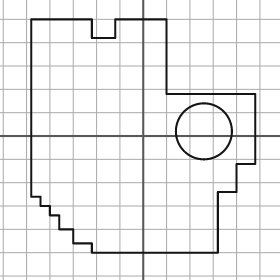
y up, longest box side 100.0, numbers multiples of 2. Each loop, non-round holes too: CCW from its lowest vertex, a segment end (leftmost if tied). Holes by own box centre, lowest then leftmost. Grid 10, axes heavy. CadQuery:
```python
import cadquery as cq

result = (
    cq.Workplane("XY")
    .moveTo(-22.0, -50.0)
    .lineTo(32.0, -50.0)
    .lineTo(32.0, -24.0)
    .lineTo(40.0, -24.0)
    .lineTo(40.0, -12.0)
    .lineTo(48.0, -12.0)
    .lineTo(48.0, 18.0)
    .lineTo(10.0, 18.0)
    .lineTo(10.0, 50.0)
    .lineTo(-12.0, 50.0)
    .lineTo(-12.0, 42.0)
    .lineTo(-22.0, 42.0)
    .lineTo(-22.0, 50.0)
    .lineTo(-48.0, 50.0)
    .lineTo(-48.0, -26.0)
    .lineTo(-44.0, -26.0)
    .lineTo(-44.0, -30.0)
    .lineTo(-40.0, -30.0)
    .lineTo(-40.0, -34.0)
    .lineTo(-36.0, -34.0)
    .lineTo(-36.0, -40.0)
    .lineTo(-30.0, -40.0)
    .lineTo(-30.0, -46.0)
    .lineTo(-22.0, -46.0)
    .close()
    .moveTo(26.0, 2.0)
    .circle(12.0)
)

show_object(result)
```